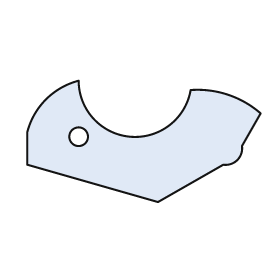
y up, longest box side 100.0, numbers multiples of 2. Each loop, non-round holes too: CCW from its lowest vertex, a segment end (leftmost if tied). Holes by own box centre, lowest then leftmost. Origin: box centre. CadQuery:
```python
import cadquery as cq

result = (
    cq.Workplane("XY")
    .moveTo(6.0, -26.0)
    .lineTo(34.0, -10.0)
    .threePointArc((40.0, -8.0), (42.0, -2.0))
    .lineTo(50.0, 12.0)
    .threePointArc((36.0, 20.0), (20.0, 22.0))
    .threePointArc((-6.0, 2.0), (-28.0, 26.0))
    .threePointArc((-42.0, 18.0), (-50.0, 4.0))
    .lineTo(-50.0, -10.0)
    .close()
    .moveTo(-28.0, 2.0)
    .circle(4.0)
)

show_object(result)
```